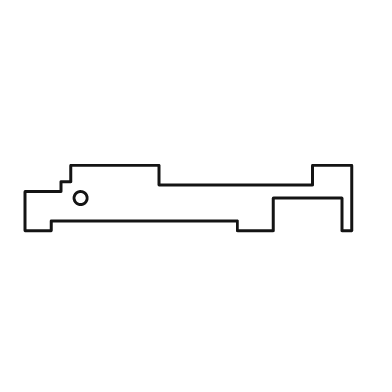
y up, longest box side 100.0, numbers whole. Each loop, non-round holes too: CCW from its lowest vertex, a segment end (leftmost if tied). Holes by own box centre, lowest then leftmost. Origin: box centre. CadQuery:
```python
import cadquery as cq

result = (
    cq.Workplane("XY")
    .moveTo(-50.0, -10.0)
    .lineTo(-42.0, -10.0)
    .lineTo(-42.0, -7.0)
    .lineTo(15.0, -7.0)
    .lineTo(15.0, -10.0)
    .lineTo(26.0, -10.0)
    .lineTo(26.0, 0.0)
    .lineTo(47.0, 0.0)
    .lineTo(47.0, -10.0)
    .lineTo(50.0, -10.0)
    .lineTo(50.0, 10.0)
    .lineTo(38.0, 10.0)
    .lineTo(38.0, 4.0)
    .lineTo(-9.0, 4.0)
    .lineTo(-9.0, 10.0)
    .lineTo(-36.0, 10.0)
    .lineTo(-36.0, 5.0)
    .lineTo(-39.0, 5.0)
    .lineTo(-39.0, 2.0)
    .lineTo(-50.0, 2.0)
    .close()
    .moveTo(-33.0, 0.0)
    .circle(2.0)
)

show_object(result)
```